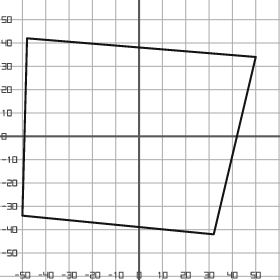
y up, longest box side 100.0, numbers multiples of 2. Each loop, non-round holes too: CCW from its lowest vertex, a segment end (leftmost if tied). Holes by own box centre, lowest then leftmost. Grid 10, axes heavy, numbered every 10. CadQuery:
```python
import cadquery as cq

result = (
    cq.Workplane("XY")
    .moveTo(32.0, -42.0)
    .lineTo(50.0, 34.0)
    .lineTo(-48.0, 42.0)
    .lineTo(-50.0, -34.0)
    .close()
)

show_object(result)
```